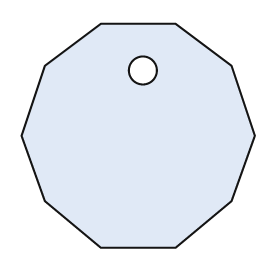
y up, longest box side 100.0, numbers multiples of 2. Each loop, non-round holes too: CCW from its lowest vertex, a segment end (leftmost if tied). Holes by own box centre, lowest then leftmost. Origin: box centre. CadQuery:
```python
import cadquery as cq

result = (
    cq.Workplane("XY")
    .moveTo(-16.0, -48.0)
    .lineTo(16.0, -48.0)
    .lineTo(40.0, -28.0)
    .lineTo(50.0, 0.0)
    .lineTo(40.0, 30.0)
    .lineTo(16.0, 48.0)
    .lineTo(-16.0, 48.0)
    .lineTo(-40.0, 30.0)
    .lineTo(-50.0, 0.0)
    .lineTo(-40.0, -28.0)
    .close()
    .moveTo(2.0, 28.0)
    .circle(6.0)
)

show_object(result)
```